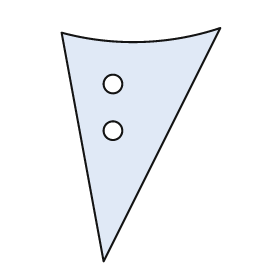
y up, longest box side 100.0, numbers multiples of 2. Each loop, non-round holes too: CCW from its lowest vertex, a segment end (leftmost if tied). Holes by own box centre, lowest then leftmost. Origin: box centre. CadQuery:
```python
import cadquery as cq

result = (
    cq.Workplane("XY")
    .moveTo(-16.0, -50.0)
    .lineTo(34.0, 50.0)
    .threePointArc((0.0, 44.0), (-34.0, 48.0))
    .close()
    .moveTo(-12.0, 6.0)
    .circle(4.0)
    .moveTo(-12.0, 26.0)
    .circle(4.0)
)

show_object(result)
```